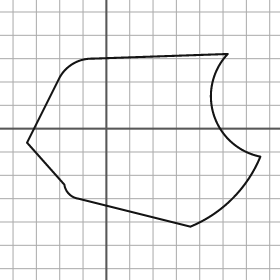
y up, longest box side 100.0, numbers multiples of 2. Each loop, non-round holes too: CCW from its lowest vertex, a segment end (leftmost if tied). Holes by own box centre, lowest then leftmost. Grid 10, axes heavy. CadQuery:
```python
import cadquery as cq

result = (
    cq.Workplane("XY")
    .moveTo(36.0, -42.0)
    .threePointArc((54.0, -30.0), (66.0, -12.0))
    .threePointArc((46.0, 6.0), (52.0, 32.0))
    .lineTo(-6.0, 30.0)
    .threePointArc((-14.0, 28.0), (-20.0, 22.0))
    .lineTo(-34.0, -6.0)
    .lineTo(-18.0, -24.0)
    .threePointArc((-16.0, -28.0), (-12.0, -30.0))
    .close()
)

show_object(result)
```